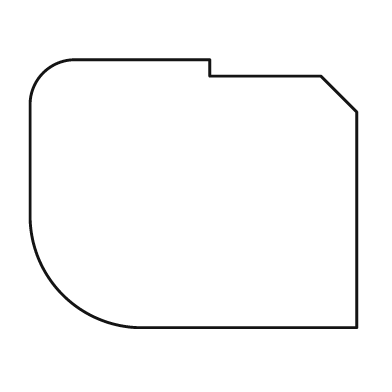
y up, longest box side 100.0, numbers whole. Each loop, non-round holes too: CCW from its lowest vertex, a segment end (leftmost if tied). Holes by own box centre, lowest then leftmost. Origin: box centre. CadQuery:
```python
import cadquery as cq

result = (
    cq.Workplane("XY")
    .moveTo(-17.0, -41.0)
    .lineTo(50.0, -41.0)
    .lineTo(50.0, 25.0)
    .lineTo(39.0, 36.0)
    .lineTo(5.0, 36.0)
    .lineTo(5.0, 41.0)
    .lineTo(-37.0, 41.0)
    .threePointArc((-46.0, 37.0), (-50.0, 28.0))
    .lineTo(-50.0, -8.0)
    .threePointArc((-40.0, -31.0), (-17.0, -41.0))
    .close()
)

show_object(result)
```